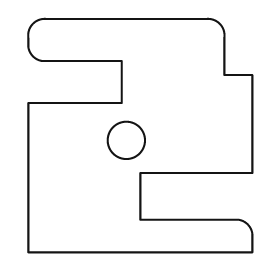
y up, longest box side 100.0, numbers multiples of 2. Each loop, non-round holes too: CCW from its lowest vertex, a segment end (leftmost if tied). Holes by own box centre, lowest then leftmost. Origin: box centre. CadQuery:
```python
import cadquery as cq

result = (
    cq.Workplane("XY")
    .moveTo(-48.0, -50.0)
    .lineTo(48.0, -50.0)
    .lineTo(48.0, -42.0)
    .threePointArc((46.0, -38.0), (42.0, -36.0))
    .lineTo(0.0, -36.0)
    .lineTo(0.0, -16.0)
    .lineTo(48.0, -16.0)
    .lineTo(48.0, 26.0)
    .lineTo(36.0, 26.0)
    .lineTo(36.0, 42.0)
    .threePointArc((34.0, 48.0), (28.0, 50.0))
    .lineTo(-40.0, 50.0)
    .threePointArc((-46.0, 48.0), (-48.0, 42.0))
    .lineTo(-48.0, 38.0)
    .threePointArc((-46.0, 34.0), (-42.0, 32.0))
    .lineTo(-8.0, 32.0)
    .lineTo(-8.0, 14.0)
    .lineTo(-48.0, 14.0)
    .close()
    .moveTo(-6.0, -2.0)
    .circle(8.0)
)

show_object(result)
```